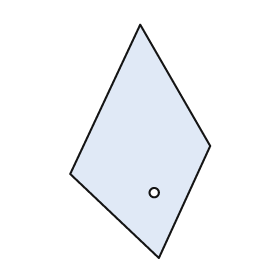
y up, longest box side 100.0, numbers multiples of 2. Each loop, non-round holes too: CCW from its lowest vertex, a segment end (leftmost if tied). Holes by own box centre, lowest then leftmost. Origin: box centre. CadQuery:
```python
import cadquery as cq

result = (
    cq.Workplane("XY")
    .moveTo(8.0, -50.0)
    .lineTo(30.0, -2.0)
    .lineTo(0.0, 50.0)
    .lineTo(-30.0, -14.0)
    .close()
    .moveTo(6.0, -22.0)
    .circle(2.0)
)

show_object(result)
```